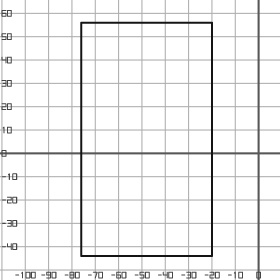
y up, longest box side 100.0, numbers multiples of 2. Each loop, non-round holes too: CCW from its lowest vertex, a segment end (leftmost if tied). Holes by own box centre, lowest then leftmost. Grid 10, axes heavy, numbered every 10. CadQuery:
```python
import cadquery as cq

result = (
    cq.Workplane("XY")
    .moveTo(-76.0, -44.0)
    .lineTo(-20.0, -44.0)
    .lineTo(-20.0, 56.0)
    .lineTo(-76.0, 56.0)
    .close()
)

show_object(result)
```